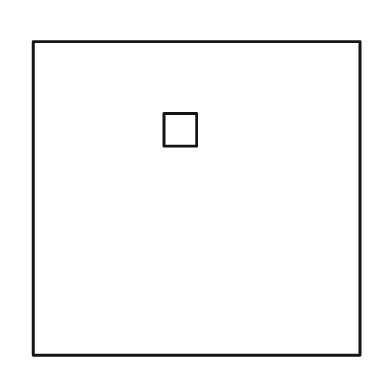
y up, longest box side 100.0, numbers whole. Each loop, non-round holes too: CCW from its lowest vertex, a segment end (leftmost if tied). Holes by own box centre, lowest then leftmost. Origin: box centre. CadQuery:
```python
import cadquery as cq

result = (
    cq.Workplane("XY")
    .moveTo(-50.0, -48.0)
    .lineTo(50.0, -48.0)
    .lineTo(50.0, 48.0)
    .lineTo(-50.0, 48.0)
    .close()
    .moveTo(-10.0, 16.0)
    .lineTo(0.0, 16.0)
    .lineTo(0.0, 26.0)
    .lineTo(-10.0, 26.0)
    .close()
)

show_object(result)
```